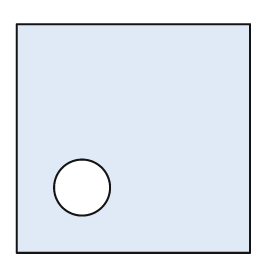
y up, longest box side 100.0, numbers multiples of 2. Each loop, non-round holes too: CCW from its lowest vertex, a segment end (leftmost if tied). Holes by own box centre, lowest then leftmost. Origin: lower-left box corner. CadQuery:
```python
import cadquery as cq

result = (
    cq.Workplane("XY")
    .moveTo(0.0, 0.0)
    .lineTo(100.0, 0.0)
    .lineTo(100.0, 98.0)
    .lineTo(0.0, 98.0)
    .close()
    .moveTo(28.0, 28.0)
    .circle(12.0)
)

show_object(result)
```